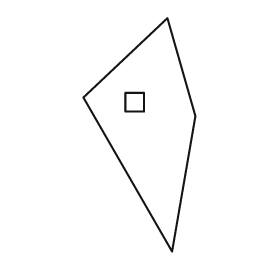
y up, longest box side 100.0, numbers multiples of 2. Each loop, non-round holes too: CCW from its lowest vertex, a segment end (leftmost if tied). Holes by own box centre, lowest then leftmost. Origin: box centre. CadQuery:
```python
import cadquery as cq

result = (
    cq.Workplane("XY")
    .moveTo(14.0, -50.0)
    .lineTo(24.0, 8.0)
    .lineTo(12.0, 50.0)
    .lineTo(-24.0, 16.0)
    .close()
    .moveTo(-6.0, 10.0)
    .lineTo(2.0, 10.0)
    .lineTo(2.0, 18.0)
    .lineTo(-6.0, 18.0)
    .close()
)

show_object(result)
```